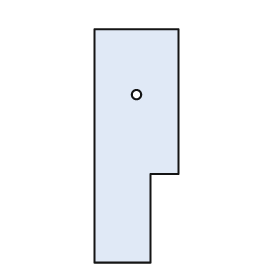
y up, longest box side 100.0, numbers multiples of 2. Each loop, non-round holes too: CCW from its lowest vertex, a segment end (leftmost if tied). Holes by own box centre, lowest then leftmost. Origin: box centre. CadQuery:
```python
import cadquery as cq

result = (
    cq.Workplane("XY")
    .moveTo(-18.0, -50.0)
    .lineTo(6.0, -50.0)
    .lineTo(6.0, -12.0)
    .lineTo(18.0, -12.0)
    .lineTo(18.0, 50.0)
    .lineTo(-18.0, 50.0)
    .close()
    .moveTo(0.0, 22.0)
    .circle(2.0)
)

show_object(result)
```